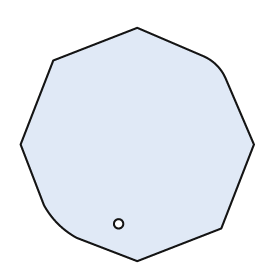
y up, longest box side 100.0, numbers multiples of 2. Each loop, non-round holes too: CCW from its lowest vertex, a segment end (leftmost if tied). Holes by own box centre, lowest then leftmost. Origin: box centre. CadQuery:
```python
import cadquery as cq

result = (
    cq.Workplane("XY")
    .moveTo(0.0, -50.0)
    .lineTo(36.0, -36.0)
    .lineTo(50.0, 0.0)
    .lineTo(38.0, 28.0)
    .threePointArc((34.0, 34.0), (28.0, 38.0))
    .lineTo(0.0, 50.0)
    .lineTo(-36.0, 36.0)
    .lineTo(-50.0, 0.0)
    .lineTo(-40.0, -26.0)
    .threePointArc((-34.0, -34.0), (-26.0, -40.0))
    .close()
    .moveTo(-8.0, -34.0)
    .circle(2.0)
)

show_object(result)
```